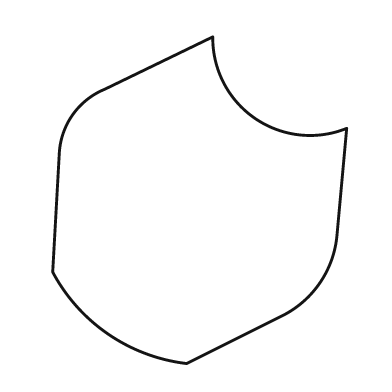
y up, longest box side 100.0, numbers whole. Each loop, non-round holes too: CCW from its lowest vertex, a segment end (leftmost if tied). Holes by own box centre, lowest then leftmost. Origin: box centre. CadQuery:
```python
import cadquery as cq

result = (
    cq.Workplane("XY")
    .moveTo(-4.0, -50.0)
    .lineTo(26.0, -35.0)
    .threePointArc((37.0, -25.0), (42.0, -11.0))
    .lineTo(45.0, 22.0)
    .threePointArc((17.0, 25.0), (4.0, 50.0))
    .lineTo(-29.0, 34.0)
    .threePointArc((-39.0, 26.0), (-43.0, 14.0))
    .lineTo(-45.0, -22.0)
    .threePointArc((-28.0, -41.0), (-4.0, -50.0))
    .close()
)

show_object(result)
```